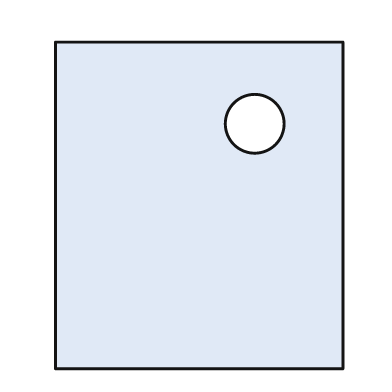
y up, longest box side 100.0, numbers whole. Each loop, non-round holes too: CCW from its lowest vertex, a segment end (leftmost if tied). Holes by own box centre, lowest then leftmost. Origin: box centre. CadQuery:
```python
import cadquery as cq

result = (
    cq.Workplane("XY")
    .moveTo(-44.0, -50.0)
    .lineTo(44.0, -50.0)
    .lineTo(44.0, 50.0)
    .lineTo(-44.0, 50.0)
    .close()
    .moveTo(17.0, 25.0)
    .circle(9.0)
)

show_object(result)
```